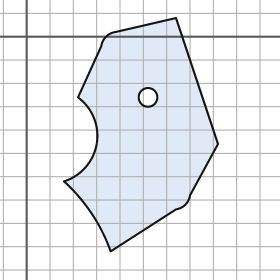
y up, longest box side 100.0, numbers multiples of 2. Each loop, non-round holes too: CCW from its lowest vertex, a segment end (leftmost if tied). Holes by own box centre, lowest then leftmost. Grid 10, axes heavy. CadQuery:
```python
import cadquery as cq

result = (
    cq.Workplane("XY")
    .moveTo(36.0, -92.0)
    .lineTo(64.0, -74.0)
    .threePointArc((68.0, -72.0), (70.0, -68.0))
    .lineTo(82.0, -46.0)
    .lineTo(64.0, 8.0)
    .lineTo(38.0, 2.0)
    .threePointArc((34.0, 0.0), (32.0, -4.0))
    .lineTo(22.0, -26.0)
    .threePointArc((30.0, -46.0), (16.0, -62.0))
    .threePointArc((28.0, -76.0), (36.0, -92.0))
    .close()
    .moveTo(52.0, -26.0)
    .circle(4.0)
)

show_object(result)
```